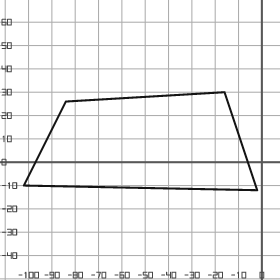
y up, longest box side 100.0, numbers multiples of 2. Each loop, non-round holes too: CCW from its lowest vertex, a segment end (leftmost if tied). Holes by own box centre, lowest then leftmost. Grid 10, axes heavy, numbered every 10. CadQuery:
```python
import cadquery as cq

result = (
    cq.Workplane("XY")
    .moveTo(-2.0, -12.0)
    .lineTo(-16.0, 30.0)
    .lineTo(-84.0, 26.0)
    .lineTo(-102.0, -10.0)
    .close()
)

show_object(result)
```